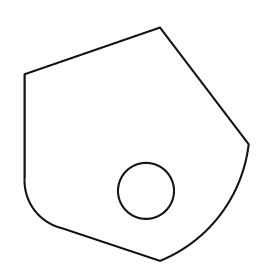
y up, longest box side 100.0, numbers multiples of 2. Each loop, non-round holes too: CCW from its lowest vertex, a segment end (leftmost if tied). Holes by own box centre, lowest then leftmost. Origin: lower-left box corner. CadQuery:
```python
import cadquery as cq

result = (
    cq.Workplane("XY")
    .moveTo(58.0, 0.0)
    .threePointArc((84.0, 20.0), (96.0, 50.0))
    .lineTo(58.0, 100.0)
    .lineTo(0.0, 80.0)
    .lineTo(0.0, 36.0)
    .threePointArc((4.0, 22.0), (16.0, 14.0))
    .close()
    .moveTo(52.0, 30.0)
    .circle(12.0)
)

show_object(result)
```